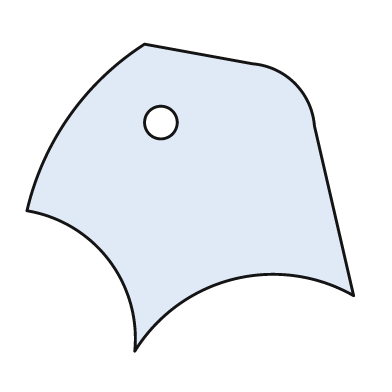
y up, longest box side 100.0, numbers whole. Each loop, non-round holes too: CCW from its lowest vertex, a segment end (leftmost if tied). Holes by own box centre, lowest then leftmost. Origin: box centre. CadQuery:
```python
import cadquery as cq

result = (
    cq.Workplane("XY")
    .moveTo(-17.0, -47.0)
    .threePointArc((13.0, -25.0), (50.0, -30.0))
    .lineTo(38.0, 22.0)
    .threePointArc((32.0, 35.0), (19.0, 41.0))
    .lineTo(-14.0, 47.0)
    .threePointArc((-37.0, 25.0), (-50.0, -4.0))
    .threePointArc((-25.0, -19.0), (-17.0, -47.0))
    .close()
    .moveTo(-9.0, 23.0)
    .circle(5.0)
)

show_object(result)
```